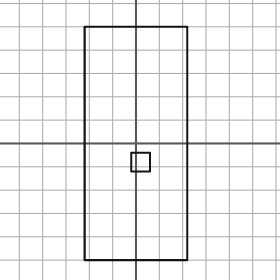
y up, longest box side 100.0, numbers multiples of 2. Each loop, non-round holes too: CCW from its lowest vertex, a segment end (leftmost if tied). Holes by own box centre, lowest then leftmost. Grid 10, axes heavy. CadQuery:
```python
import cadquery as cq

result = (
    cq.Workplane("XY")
    .moveTo(-22.0, -50.0)
    .lineTo(22.0, -50.0)
    .lineTo(22.0, 50.0)
    .lineTo(-22.0, 50.0)
    .close()
    .moveTo(-2.0, -12.0)
    .lineTo(6.0, -12.0)
    .lineTo(6.0, -4.0)
    .lineTo(-2.0, -4.0)
    .close()
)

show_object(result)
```